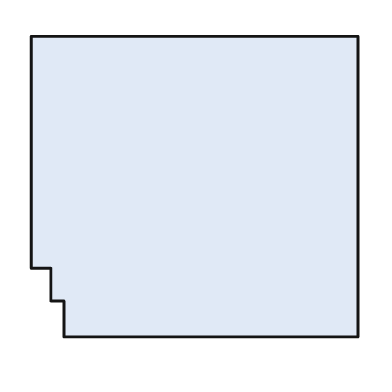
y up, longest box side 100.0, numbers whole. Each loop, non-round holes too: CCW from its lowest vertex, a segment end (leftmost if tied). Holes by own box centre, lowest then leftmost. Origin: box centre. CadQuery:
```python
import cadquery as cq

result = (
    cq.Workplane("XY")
    .moveTo(-40.0, -46.0)
    .lineTo(50.0, -46.0)
    .lineTo(50.0, 46.0)
    .lineTo(-50.0, 46.0)
    .lineTo(-50.0, -25.0)
    .lineTo(-44.0, -25.0)
    .lineTo(-44.0, -35.0)
    .lineTo(-40.0, -35.0)
    .close()
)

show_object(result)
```